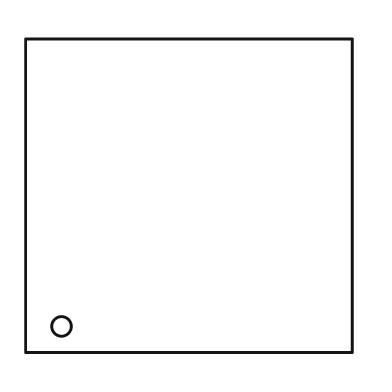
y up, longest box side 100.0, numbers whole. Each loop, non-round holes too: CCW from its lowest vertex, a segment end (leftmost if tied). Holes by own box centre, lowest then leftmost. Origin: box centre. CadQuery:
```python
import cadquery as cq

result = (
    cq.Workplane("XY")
    .moveTo(-50.0, -48.0)
    .lineTo(50.0, -48.0)
    .lineTo(50.0, 48.0)
    .lineTo(-50.0, 48.0)
    .close()
    .moveTo(-39.0, -40.0)
    .circle(3.0)
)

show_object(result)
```